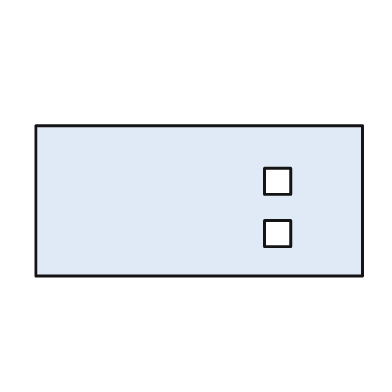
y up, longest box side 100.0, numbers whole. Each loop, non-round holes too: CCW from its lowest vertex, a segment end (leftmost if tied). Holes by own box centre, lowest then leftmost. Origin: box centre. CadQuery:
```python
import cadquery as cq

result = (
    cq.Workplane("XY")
    .moveTo(-50.0, -23.0)
    .lineTo(50.0, -23.0)
    .lineTo(50.0, 23.0)
    .lineTo(-50.0, 23.0)
    .close()
    .moveTo(20.0, -14.0)
    .lineTo(28.0, -14.0)
    .lineTo(28.0, -6.0)
    .lineTo(20.0, -6.0)
    .close()
    .moveTo(20.0, 2.0)
    .lineTo(28.0, 2.0)
    .lineTo(28.0, 10.0)
    .lineTo(20.0, 10.0)
    .close()
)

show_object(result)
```